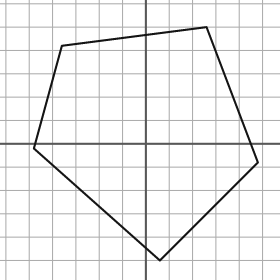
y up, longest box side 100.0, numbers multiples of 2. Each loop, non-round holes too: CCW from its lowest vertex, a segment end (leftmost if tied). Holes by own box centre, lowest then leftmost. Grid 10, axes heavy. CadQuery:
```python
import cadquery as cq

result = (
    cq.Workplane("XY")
    .moveTo(6.0, -50.0)
    .lineTo(48.0, -8.0)
    .lineTo(26.0, 50.0)
    .lineTo(-36.0, 42.0)
    .lineTo(-48.0, -2.0)
    .close()
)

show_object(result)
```